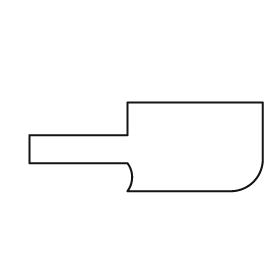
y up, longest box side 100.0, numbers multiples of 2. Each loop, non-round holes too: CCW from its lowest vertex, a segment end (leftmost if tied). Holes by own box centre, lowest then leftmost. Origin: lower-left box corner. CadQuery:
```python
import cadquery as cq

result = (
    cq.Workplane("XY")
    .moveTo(42.0, 0.0)
    .lineTo(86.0, 0.0)
    .threePointArc((96.0, 4.0), (100.0, 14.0))
    .lineTo(100.0, 38.0)
    .lineTo(42.0, 38.0)
    .lineTo(42.0, 24.0)
    .lineTo(0.0, 24.0)
    .lineTo(0.0, 12.0)
    .lineTo(42.0, 12.0)
    .threePointArc((44.0, 6.0), (42.0, 0.0))
    .close()
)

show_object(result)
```